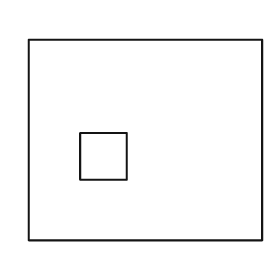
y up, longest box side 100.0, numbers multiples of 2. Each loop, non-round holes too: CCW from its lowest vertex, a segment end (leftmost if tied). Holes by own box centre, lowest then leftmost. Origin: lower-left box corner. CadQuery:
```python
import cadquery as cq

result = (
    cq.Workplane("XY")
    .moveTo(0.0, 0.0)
    .lineTo(100.0, 0.0)
    .lineTo(100.0, 86.0)
    .lineTo(0.0, 86.0)
    .close()
    .moveTo(22.0, 26.0)
    .lineTo(42.0, 26.0)
    .lineTo(42.0, 46.0)
    .lineTo(22.0, 46.0)
    .close()
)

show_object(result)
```